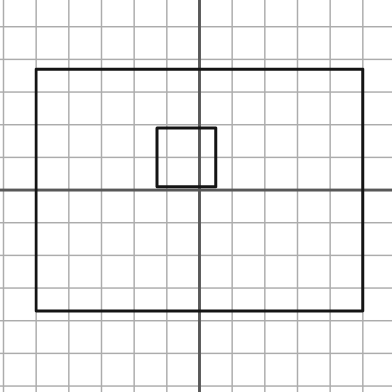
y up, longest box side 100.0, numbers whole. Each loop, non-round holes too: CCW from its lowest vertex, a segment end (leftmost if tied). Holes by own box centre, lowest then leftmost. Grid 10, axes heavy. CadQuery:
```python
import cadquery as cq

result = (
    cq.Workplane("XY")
    .moveTo(-50.0, -37.0)
    .lineTo(50.0, -37.0)
    .lineTo(50.0, 37.0)
    .lineTo(-50.0, 37.0)
    .close()
    .moveTo(-13.0, 1.0)
    .lineTo(5.0, 1.0)
    .lineTo(5.0, 19.0)
    .lineTo(-13.0, 19.0)
    .close()
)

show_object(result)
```